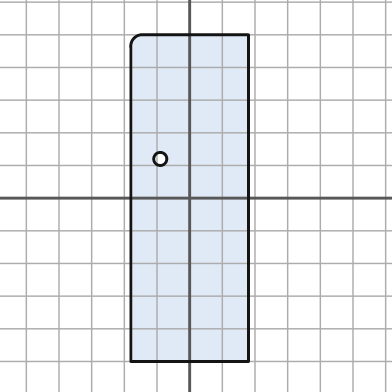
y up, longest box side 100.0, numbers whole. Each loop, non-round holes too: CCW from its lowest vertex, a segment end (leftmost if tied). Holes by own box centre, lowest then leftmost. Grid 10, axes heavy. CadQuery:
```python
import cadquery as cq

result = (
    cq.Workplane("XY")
    .moveTo(-18.0, -50.0)
    .lineTo(18.0, -50.0)
    .lineTo(18.0, 50.0)
    .lineTo(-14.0, 50.0)
    .threePointArc((-17.0, 49.0), (-18.0, 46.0))
    .close()
    .moveTo(-9.0, 12.0)
    .circle(2.0)
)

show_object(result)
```